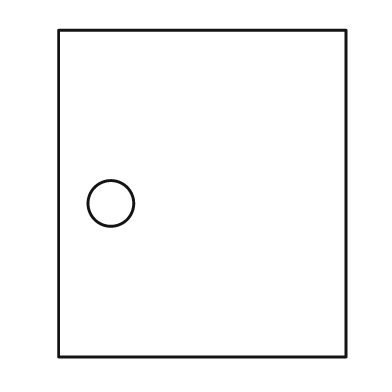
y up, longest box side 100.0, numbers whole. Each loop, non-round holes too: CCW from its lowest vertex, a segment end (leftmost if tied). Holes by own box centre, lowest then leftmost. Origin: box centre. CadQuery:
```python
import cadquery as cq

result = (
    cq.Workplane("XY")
    .moveTo(-44.0, -50.0)
    .lineTo(44.0, -50.0)
    .lineTo(44.0, 50.0)
    .lineTo(-44.0, 50.0)
    .close()
    .moveTo(-28.0, -3.0)
    .circle(7.0)
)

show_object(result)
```